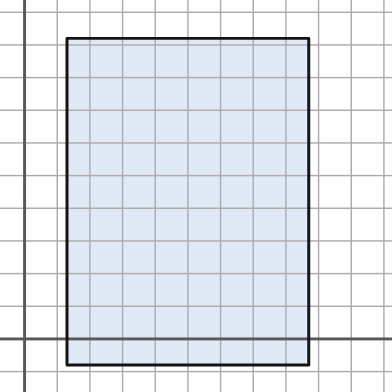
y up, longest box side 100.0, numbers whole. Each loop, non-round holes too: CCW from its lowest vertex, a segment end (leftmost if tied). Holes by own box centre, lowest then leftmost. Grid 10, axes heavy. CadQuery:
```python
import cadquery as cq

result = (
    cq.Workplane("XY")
    .moveTo(13.0, -8.0)
    .lineTo(87.0, -8.0)
    .lineTo(87.0, 92.0)
    .lineTo(13.0, 92.0)
    .close()
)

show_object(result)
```